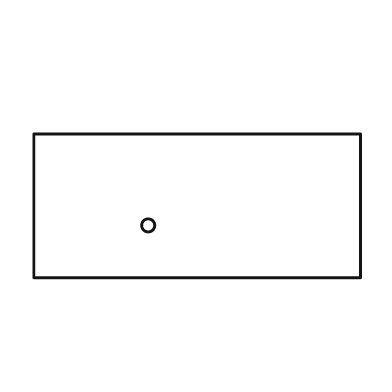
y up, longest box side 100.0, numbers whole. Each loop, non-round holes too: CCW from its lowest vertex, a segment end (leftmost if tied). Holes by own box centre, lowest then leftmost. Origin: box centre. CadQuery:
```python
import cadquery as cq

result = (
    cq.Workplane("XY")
    .moveTo(-50.0, -22.0)
    .lineTo(50.0, -22.0)
    .lineTo(50.0, 22.0)
    .lineTo(-50.0, 22.0)
    .close()
    .moveTo(-15.0, -6.0)
    .circle(2.0)
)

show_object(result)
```